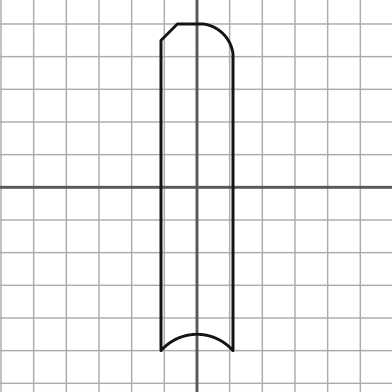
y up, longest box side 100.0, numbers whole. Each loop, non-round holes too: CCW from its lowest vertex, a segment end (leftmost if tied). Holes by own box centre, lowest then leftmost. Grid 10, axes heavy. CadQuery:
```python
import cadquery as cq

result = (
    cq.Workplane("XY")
    .moveTo(-11.0, -50.0)
    .threePointArc((0.0, -45.0), (11.0, -50.0))
    .lineTo(11.0, 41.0)
    .threePointArc((8.0, 47.0), (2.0, 50.0))
    .lineTo(-6.0, 50.0)
    .lineTo(-11.0, 45.0)
    .close()
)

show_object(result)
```